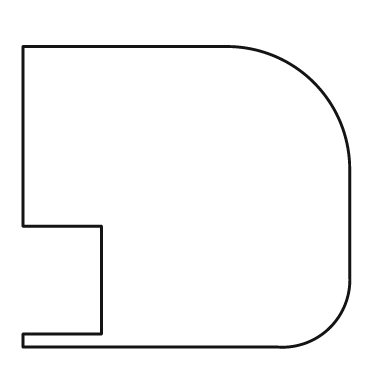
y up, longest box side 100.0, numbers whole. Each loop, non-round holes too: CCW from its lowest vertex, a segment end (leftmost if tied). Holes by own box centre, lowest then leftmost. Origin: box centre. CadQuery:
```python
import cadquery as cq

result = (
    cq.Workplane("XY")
    .moveTo(-50.0, -46.0)
    .lineTo(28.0, -46.0)
    .threePointArc((44.0, -40.0), (50.0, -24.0))
    .lineTo(50.0, 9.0)
    .threePointArc((39.0, 35.0), (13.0, 46.0))
    .lineTo(-50.0, 46.0)
    .lineTo(-50.0, -9.0)
    .lineTo(-26.0, -9.0)
    .lineTo(-26.0, -42.0)
    .lineTo(-50.0, -42.0)
    .close()
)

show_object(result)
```